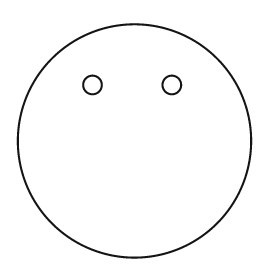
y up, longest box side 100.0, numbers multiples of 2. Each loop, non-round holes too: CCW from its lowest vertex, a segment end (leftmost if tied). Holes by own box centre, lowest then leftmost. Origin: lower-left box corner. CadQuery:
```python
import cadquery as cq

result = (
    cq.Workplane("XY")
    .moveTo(50.0, 50.0)
    .circle(50.0)
    .moveTo(32.0, 74.0)
    .circle(4.0)
    .moveTo(66.0, 74.0)
    .circle(4.0)
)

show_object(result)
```